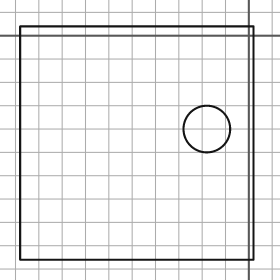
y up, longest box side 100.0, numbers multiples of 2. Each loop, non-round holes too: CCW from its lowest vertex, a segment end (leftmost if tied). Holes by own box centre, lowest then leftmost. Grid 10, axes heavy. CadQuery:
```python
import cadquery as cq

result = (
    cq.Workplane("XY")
    .moveTo(-98.0, -96.0)
    .lineTo(2.0, -96.0)
    .lineTo(2.0, 4.0)
    .lineTo(-98.0, 4.0)
    .close()
    .moveTo(-18.0, -40.0)
    .circle(10.0)
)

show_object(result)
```